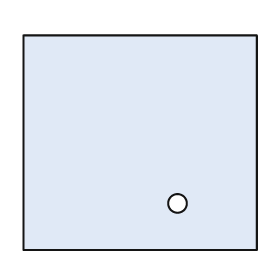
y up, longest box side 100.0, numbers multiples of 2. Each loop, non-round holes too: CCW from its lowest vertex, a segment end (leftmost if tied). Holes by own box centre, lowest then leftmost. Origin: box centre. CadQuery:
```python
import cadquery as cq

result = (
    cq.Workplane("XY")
    .moveTo(-50.0, -46.0)
    .lineTo(50.0, -46.0)
    .lineTo(50.0, 46.0)
    .lineTo(-50.0, 46.0)
    .close()
    .moveTo(16.0, -26.0)
    .circle(4.0)
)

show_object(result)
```